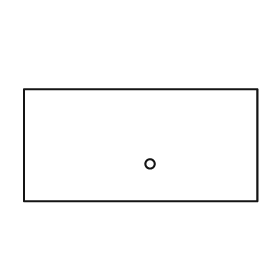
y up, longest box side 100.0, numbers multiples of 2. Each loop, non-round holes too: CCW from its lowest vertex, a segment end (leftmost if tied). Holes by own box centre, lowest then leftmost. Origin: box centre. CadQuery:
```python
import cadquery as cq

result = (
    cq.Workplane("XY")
    .moveTo(-50.0, -24.0)
    .lineTo(50.0, -24.0)
    .lineTo(50.0, 24.0)
    .lineTo(-50.0, 24.0)
    .close()
    .moveTo(4.0, -8.0)
    .circle(2.0)
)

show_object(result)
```